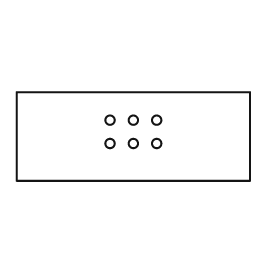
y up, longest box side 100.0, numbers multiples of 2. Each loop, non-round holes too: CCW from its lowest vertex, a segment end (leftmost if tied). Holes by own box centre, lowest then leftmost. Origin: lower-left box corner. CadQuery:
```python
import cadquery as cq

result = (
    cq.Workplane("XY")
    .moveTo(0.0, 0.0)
    .lineTo(100.0, 0.0)
    .lineTo(100.0, 38.0)
    .lineTo(0.0, 38.0)
    .close()
    .moveTo(40.0, 16.0)
    .circle(2.0)
    .moveTo(50.0, 16.0)
    .circle(2.0)
    .moveTo(60.0, 16.0)
    .circle(2.0)
    .moveTo(40.0, 26.0)
    .circle(2.0)
    .moveTo(50.0, 26.0)
    .circle(2.0)
    .moveTo(60.0, 26.0)
    .circle(2.0)
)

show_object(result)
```